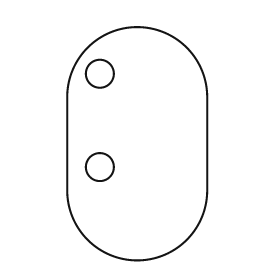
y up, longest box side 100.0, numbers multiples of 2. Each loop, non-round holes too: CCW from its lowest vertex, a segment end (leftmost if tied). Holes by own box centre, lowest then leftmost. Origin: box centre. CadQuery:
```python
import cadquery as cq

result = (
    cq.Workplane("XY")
    .moveTo(-30.0, -20.0)
    .threePointArc((0.0, -50.0), (30.0, -20.0))
    .lineTo(30.0, 20.0)
    .threePointArc((0.0, 50.0), (-30.0, 20.0))
    .close()
    .moveTo(-16.0, -10.0)
    .circle(6.0)
    .moveTo(-16.0, 30.0)
    .circle(6.0)
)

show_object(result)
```